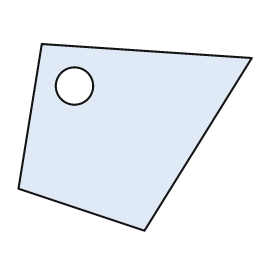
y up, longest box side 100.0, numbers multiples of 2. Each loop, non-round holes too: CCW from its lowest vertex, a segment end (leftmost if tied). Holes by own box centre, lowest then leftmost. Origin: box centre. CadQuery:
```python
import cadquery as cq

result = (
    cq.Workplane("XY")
    .moveTo(4.0, -40.0)
    .lineTo(50.0, 34.0)
    .lineTo(-40.0, 40.0)
    .lineTo(-50.0, -22.0)
    .close()
    .moveTo(-26.0, 22.0)
    .circle(8.0)
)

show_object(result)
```